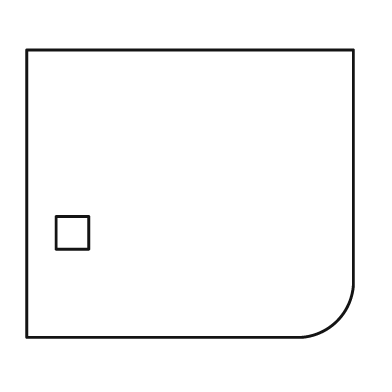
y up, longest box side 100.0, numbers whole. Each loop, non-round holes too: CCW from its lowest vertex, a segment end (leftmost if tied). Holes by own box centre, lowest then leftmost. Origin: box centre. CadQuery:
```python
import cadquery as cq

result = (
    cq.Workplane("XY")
    .moveTo(-50.0, -44.0)
    .lineTo(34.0, -44.0)
    .threePointArc((45.0, -39.0), (50.0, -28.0))
    .lineTo(50.0, 44.0)
    .lineTo(-50.0, 44.0)
    .close()
    .moveTo(-41.0, -17.0)
    .lineTo(-31.0, -17.0)
    .lineTo(-31.0, -7.0)
    .lineTo(-41.0, -7.0)
    .close()
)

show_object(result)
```